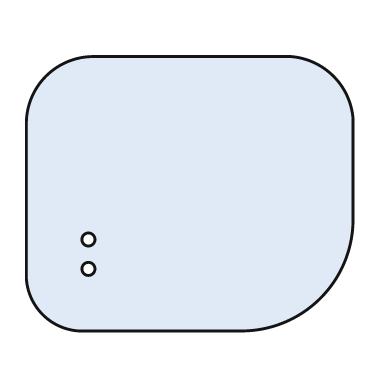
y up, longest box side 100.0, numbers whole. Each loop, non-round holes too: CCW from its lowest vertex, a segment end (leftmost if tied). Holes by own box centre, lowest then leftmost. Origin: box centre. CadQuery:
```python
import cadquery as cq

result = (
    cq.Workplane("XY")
    .moveTo(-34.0, -42.0)
    .lineTo(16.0, -42.0)
    .threePointArc((40.0, -32.0), (50.0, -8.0))
    .lineTo(50.0, 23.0)
    .threePointArc((44.0, 36.0), (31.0, 42.0))
    .lineTo(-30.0, 42.0)
    .threePointArc((-44.0, 36.0), (-50.0, 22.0))
    .lineTo(-50.0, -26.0)
    .threePointArc((-45.0, -37.0), (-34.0, -42.0))
    .close()
    .moveTo(-31.0, -23.0)
    .circle(2.0)
    .moveTo(-31.0, -14.0)
    .circle(2.0)
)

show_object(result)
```